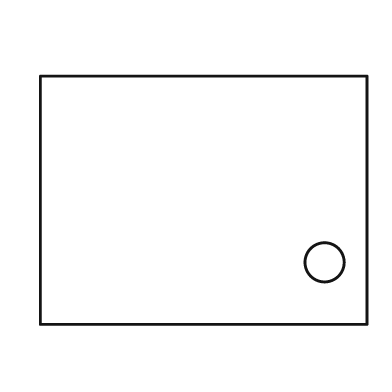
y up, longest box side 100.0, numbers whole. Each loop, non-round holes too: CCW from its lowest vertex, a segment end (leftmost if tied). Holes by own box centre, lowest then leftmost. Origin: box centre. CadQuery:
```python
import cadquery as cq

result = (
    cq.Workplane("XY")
    .moveTo(-50.0, -38.0)
    .lineTo(50.0, -38.0)
    .lineTo(50.0, 38.0)
    .lineTo(-50.0, 38.0)
    .close()
    .moveTo(37.0, -19.0)
    .circle(6.0)
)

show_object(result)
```